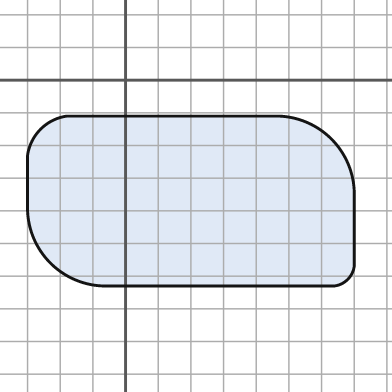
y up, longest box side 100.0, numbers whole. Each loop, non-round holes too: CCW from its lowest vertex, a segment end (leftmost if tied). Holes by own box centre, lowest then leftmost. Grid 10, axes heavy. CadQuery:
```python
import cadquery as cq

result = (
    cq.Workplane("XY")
    .moveTo(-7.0, -63.0)
    .lineTo(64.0, -63.0)
    .threePointArc((68.0, -61.0), (70.0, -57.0))
    .lineTo(70.0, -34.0)
    .threePointArc((63.0, -18.0), (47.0, -11.0))
    .lineTo(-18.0, -11.0)
    .threePointArc((-26.0, -15.0), (-30.0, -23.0))
    .lineTo(-30.0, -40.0)
    .threePointArc((-23.0, -56.0), (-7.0, -63.0))
    .close()
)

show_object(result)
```